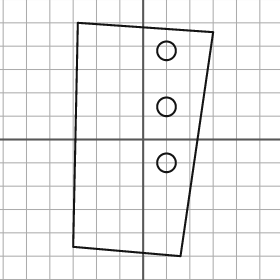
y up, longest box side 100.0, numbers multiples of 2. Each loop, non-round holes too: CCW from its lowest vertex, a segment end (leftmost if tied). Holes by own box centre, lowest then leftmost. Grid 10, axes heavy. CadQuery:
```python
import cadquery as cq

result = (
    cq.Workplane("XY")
    .moveTo(16.0, -50.0)
    .lineTo(30.0, 46.0)
    .lineTo(-28.0, 50.0)
    .lineTo(-30.0, -46.0)
    .close()
    .moveTo(10.0, -10.0)
    .circle(4.0)
    .moveTo(10.0, 14.0)
    .circle(4.0)
    .moveTo(10.0, 38.0)
    .circle(4.0)
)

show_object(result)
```